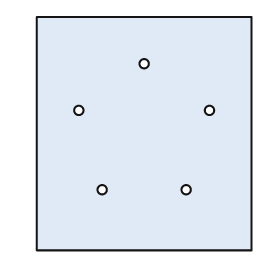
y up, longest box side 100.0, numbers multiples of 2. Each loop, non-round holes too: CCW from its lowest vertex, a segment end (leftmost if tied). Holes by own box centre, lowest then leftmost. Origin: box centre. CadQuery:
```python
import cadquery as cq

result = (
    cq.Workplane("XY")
    .moveTo(-46.0, -50.0)
    .lineTo(46.0, -50.0)
    .lineTo(46.0, 50.0)
    .lineTo(-46.0, 50.0)
    .close()
    .moveTo(-18.0, -24.0)
    .circle(2.0)
    .moveTo(18.0, -24.0)
    .circle(2.0)
    .moveTo(-28.0, 10.0)
    .circle(2.0)
    .moveTo(28.0, 10.0)
    .circle(2.0)
    .moveTo(0.0, 30.0)
    .circle(2.0)
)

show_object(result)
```